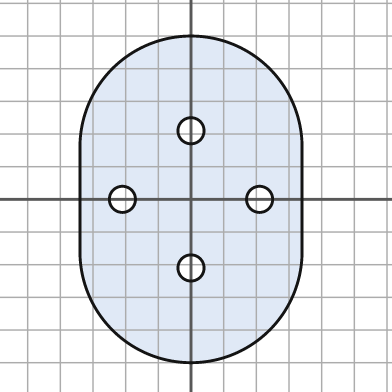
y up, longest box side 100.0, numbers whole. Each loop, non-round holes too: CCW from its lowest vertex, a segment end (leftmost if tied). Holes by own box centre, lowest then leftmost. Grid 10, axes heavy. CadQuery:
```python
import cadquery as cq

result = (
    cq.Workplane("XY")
    .moveTo(-34.0, -16.0)
    .threePointArc((0.0, -50.0), (34.0, -16.0))
    .lineTo(34.0, 16.0)
    .threePointArc((0.0, 50.0), (-34.0, 16.0))
    .close()
    .moveTo(0.0, -21.0)
    .circle(4.0)
    .moveTo(-21.0, 0.0)
    .circle(4.0)
    .moveTo(21.0, 0.0)
    .circle(4.0)
    .moveTo(0.0, 21.0)
    .circle(4.0)
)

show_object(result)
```